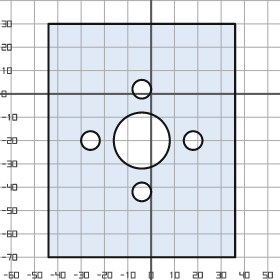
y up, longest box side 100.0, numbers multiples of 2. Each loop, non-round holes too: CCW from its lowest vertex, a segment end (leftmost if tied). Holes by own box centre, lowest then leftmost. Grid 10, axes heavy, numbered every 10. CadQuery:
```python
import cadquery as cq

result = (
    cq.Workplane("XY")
    .moveTo(-44.0, -70.0)
    .lineTo(36.0, -70.0)
    .lineTo(36.0, 30.0)
    .lineTo(-44.0, 30.0)
    .close()
    .moveTo(-4.0, -42.0)
    .circle(4.0)
    .moveTo(-26.0, -20.0)
    .circle(4.0)
    .moveTo(-4.0, -20.0)
    .circle(12.0)
    .moveTo(18.0, -20.0)
    .circle(4.0)
    .moveTo(-4.0, 2.0)
    .circle(4.0)
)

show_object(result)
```